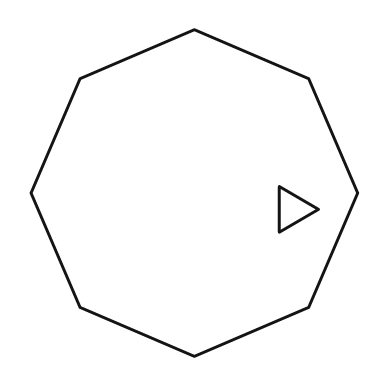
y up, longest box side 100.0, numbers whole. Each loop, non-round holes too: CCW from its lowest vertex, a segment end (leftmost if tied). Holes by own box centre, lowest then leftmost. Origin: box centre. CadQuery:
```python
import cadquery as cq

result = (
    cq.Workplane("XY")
    .moveTo(0.0, -50.0)
    .lineTo(35.0, -35.0)
    .lineTo(50.0, 0.0)
    .lineTo(35.0, 35.0)
    .lineTo(0.0, 50.0)
    .lineTo(-35.0, 35.0)
    .lineTo(-50.0, 0.0)
    .lineTo(-35.0, -35.0)
    .close()
    .moveTo(26.0, -12.0)
    .lineTo(38.0, -5.0)
    .lineTo(26.0, 2.0)
    .close()
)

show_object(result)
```